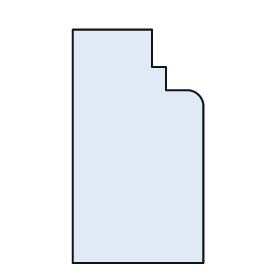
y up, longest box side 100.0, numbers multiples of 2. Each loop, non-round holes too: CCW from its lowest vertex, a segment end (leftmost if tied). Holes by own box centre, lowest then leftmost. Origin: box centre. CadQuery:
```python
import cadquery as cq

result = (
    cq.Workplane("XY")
    .moveTo(-28.0, -50.0)
    .lineTo(28.0, -50.0)
    .lineTo(28.0, 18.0)
    .threePointArc((26.0, 22.0), (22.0, 24.0))
    .lineTo(12.0, 24.0)
    .lineTo(12.0, 34.0)
    .lineTo(6.0, 34.0)
    .lineTo(6.0, 50.0)
    .lineTo(-28.0, 50.0)
    .close()
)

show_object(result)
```